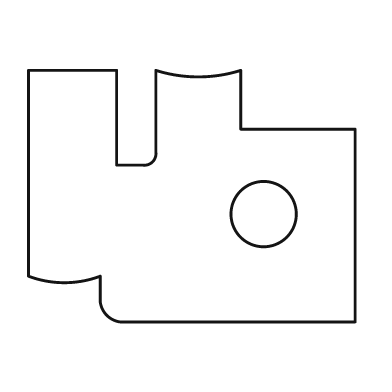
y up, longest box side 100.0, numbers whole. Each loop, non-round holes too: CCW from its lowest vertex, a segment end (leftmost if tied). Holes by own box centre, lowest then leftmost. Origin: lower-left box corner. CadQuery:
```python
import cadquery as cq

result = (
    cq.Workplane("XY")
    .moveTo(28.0, 0.0)
    .lineTo(100.0, 0.0)
    .lineTo(100.0, 59.0)
    .lineTo(65.0, 59.0)
    .lineTo(65.0, 77.0)
    .threePointArc((52.0, 75.0), (39.0, 77.0))
    .lineTo(39.0, 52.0)
    .threePointArc((38.0, 49.0), (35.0, 48.0))
    .lineTo(27.0, 48.0)
    .lineTo(27.0, 77.0)
    .lineTo(0.0, 77.0)
    .lineTo(0.0, 14.0)
    .threePointArc((11.0, 12.0), (22.0, 14.0))
    .lineTo(22.0, 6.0)
    .threePointArc((24.0, 2.0), (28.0, 0.0))
    .close()
    .moveTo(72.0, 33.0)
    .circle(10.0)
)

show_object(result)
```